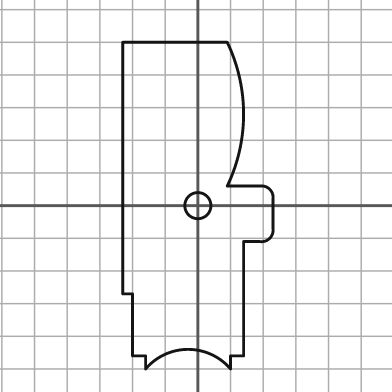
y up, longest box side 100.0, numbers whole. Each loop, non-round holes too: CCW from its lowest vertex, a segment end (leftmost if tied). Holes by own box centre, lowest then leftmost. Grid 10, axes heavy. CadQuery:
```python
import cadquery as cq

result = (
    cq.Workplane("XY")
    .moveTo(-16.0, -50.0)
    .threePointArc((-3.0, -44.0), (10.0, -50.0))
    .lineTo(10.0, -46.0)
    .lineTo(14.0, -46.0)
    .lineTo(14.0, -11.0)
    .lineTo(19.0, -11.0)
    .threePointArc((22.0, -10.0), (23.0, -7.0))
    .lineTo(23.0, 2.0)
    .threePointArc((22.0, 5.0), (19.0, 6.0))
    .lineTo(9.0, 6.0)
    .threePointArc((14.0, 28.0), (9.0, 50.0))
    .lineTo(-23.0, 50.0)
    .lineTo(-23.0, -27.0)
    .lineTo(-20.0, -27.0)
    .lineTo(-20.0, -46.0)
    .lineTo(-16.0, -46.0)
    .close()
    .moveTo(0.0, 0.0)
    .circle(4.0)
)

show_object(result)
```